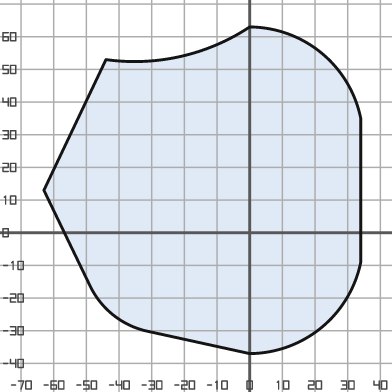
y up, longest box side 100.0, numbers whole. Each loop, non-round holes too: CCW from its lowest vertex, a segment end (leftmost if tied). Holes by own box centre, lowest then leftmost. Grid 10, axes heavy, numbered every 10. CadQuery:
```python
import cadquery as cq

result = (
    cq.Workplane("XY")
    .moveTo(0.0, -37.0)
    .threePointArc((22.0, -29.0), (34.0, -9.0))
    .lineTo(34.0, 35.0)
    .threePointArc((22.0, 55.0), (0.0, 63.0))
    .threePointArc((-21.0, 54.0), (-44.0, 53.0))
    .lineTo(-63.0, 13.0)
    .lineTo(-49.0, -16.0)
    .threePointArc((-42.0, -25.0), (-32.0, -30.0))
    .close()
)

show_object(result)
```